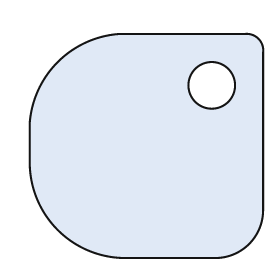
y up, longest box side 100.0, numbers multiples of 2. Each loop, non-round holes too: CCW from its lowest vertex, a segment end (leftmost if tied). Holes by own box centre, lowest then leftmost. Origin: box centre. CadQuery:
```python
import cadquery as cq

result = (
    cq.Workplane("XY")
    .moveTo(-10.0, -48.0)
    .lineTo(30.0, -48.0)
    .threePointArc((44.0, -42.0), (50.0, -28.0))
    .lineTo(50.0, 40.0)
    .threePointArc((48.0, 46.0), (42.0, 48.0))
    .lineTo(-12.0, 48.0)
    .threePointArc((-38.0, 36.0), (-50.0, 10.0))
    .lineTo(-50.0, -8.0)
    .threePointArc((-38.0, -36.0), (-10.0, -48.0))
    .close()
    .moveTo(28.0, 26.0)
    .circle(10.0)
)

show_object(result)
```